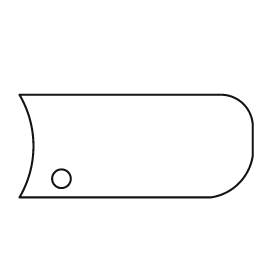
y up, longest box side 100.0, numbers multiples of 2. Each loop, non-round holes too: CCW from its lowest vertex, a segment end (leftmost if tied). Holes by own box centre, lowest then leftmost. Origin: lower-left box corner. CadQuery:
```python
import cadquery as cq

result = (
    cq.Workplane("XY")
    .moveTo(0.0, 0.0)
    .lineTo(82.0, 0.0)
    .threePointArc((94.0, 6.0), (100.0, 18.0))
    .lineTo(100.0, 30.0)
    .threePointArc((96.0, 40.0), (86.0, 44.0))
    .lineTo(0.0, 44.0)
    .threePointArc((6.0, 22.0), (0.0, 0.0))
    .close()
    .moveTo(18.0, 8.0)
    .circle(4.0)
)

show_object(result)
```